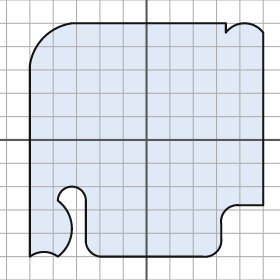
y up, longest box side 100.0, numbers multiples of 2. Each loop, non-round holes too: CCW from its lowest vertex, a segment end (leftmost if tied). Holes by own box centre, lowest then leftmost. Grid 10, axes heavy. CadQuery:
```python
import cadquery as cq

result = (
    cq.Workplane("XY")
    .moveTo(-50.0, -50.0)
    .threePointArc((-44.0, -48.0), (-38.0, -50.0))
    .threePointArc((-32.0, -38.0), (-38.0, -26.0))
    .threePointArc((-32.0, -20.0), (-26.0, -26.0))
    .lineTo(-26.0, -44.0)
    .threePointArc((-24.0, -48.0), (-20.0, -50.0))
    .lineTo(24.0, -50.0)
    .threePointArc((30.0, -48.0), (32.0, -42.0))
    .lineTo(32.0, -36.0)
    .threePointArc((34.0, -30.0), (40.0, -28.0))
    .lineTo(50.0, -28.0)
    .lineTo(50.0, 46.0)
    .threePointArc((42.0, 50.0), (34.0, 46.0))
    .lineTo(34.0, 50.0)
    .lineTo(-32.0, 50.0)
    .threePointArc((-44.0, 44.0), (-50.0, 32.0))
    .close()
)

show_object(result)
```